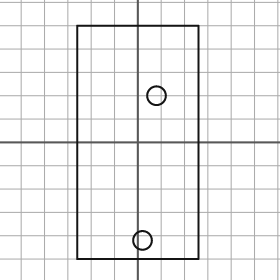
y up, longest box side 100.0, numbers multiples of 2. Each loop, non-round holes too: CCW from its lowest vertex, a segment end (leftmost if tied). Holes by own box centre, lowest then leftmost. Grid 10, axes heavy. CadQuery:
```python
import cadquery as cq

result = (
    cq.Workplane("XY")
    .moveTo(-26.0, -50.0)
    .lineTo(26.0, -50.0)
    .lineTo(26.0, 50.0)
    .lineTo(-26.0, 50.0)
    .close()
    .moveTo(2.0, -42.0)
    .circle(4.0)
    .moveTo(8.0, 20.0)
    .circle(4.0)
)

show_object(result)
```